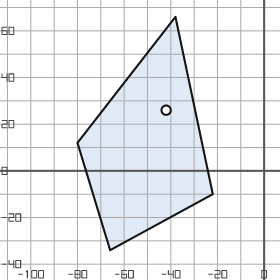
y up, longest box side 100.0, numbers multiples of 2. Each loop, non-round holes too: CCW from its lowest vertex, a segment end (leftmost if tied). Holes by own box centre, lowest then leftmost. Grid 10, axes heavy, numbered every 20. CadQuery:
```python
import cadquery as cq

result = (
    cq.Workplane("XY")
    .moveTo(-66.0, -34.0)
    .lineTo(-22.0, -10.0)
    .lineTo(-38.0, 66.0)
    .lineTo(-80.0, 12.0)
    .close()
    .moveTo(-42.0, 26.0)
    .circle(2.0)
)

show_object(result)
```